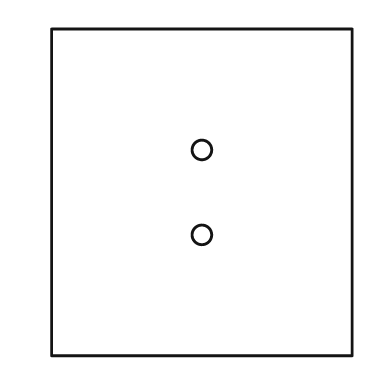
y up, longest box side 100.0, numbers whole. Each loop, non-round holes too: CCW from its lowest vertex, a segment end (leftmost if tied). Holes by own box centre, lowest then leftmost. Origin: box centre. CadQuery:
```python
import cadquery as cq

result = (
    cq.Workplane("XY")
    .moveTo(-46.0, -50.0)
    .lineTo(46.0, -50.0)
    .lineTo(46.0, 50.0)
    .lineTo(-46.0, 50.0)
    .close()
    .moveTo(0.0, -13.0)
    .circle(3.0)
    .moveTo(0.0, 13.0)
    .circle(3.0)
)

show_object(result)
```